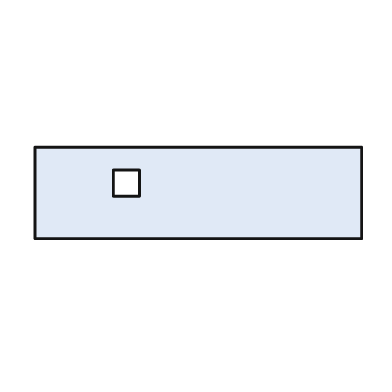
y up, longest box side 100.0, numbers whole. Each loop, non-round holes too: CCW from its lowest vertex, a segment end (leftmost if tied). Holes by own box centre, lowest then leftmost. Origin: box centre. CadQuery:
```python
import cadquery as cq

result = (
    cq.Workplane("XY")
    .moveTo(-50.0, -14.0)
    .lineTo(50.0, -14.0)
    .lineTo(50.0, 14.0)
    .lineTo(-50.0, 14.0)
    .close()
    .moveTo(-26.0, -1.0)
    .lineTo(-18.0, -1.0)
    .lineTo(-18.0, 7.0)
    .lineTo(-26.0, 7.0)
    .close()
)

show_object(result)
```